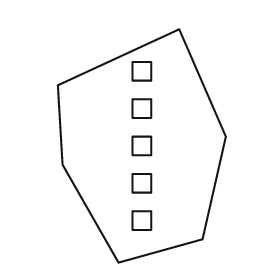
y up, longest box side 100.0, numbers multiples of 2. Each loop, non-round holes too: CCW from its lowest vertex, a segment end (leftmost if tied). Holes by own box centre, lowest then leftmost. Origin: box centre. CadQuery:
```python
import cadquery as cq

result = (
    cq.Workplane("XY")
    .moveTo(-10.0, -50.0)
    .lineTo(26.0, -40.0)
    .lineTo(36.0, 4.0)
    .lineTo(16.0, 50.0)
    .lineTo(-36.0, 26.0)
    .lineTo(-34.0, -8.0)
    .close()
    .moveTo(-4.0, -36.0)
    .lineTo(4.0, -36.0)
    .lineTo(4.0, -28.0)
    .lineTo(-4.0, -28.0)
    .close()
    .moveTo(-4.0, -20.0)
    .lineTo(4.0, -20.0)
    .lineTo(4.0, -12.0)
    .lineTo(-4.0, -12.0)
    .close()
    .moveTo(-4.0, -4.0)
    .lineTo(4.0, -4.0)
    .lineTo(4.0, 4.0)
    .lineTo(-4.0, 4.0)
    .close()
    .moveTo(-4.0, 12.0)
    .lineTo(4.0, 12.0)
    .lineTo(4.0, 20.0)
    .lineTo(-4.0, 20.0)
    .close()
    .moveTo(-4.0, 28.0)
    .lineTo(4.0, 28.0)
    .lineTo(4.0, 36.0)
    .lineTo(-4.0, 36.0)
    .close()
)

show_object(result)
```